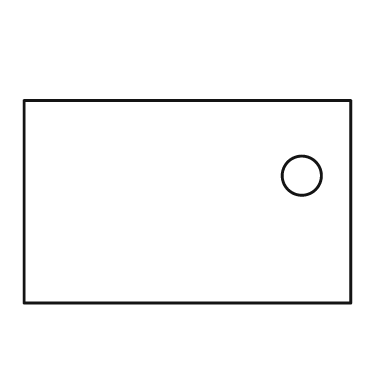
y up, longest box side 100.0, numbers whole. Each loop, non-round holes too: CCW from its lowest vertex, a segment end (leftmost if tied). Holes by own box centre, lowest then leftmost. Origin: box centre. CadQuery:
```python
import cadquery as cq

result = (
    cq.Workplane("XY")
    .moveTo(-50.0, -31.0)
    .lineTo(50.0, -31.0)
    .lineTo(50.0, 31.0)
    .lineTo(-50.0, 31.0)
    .close()
    .moveTo(35.0, 8.0)
    .circle(6.0)
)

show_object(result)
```